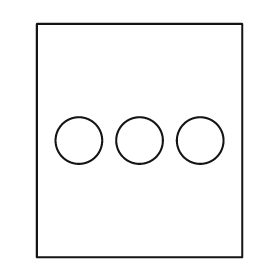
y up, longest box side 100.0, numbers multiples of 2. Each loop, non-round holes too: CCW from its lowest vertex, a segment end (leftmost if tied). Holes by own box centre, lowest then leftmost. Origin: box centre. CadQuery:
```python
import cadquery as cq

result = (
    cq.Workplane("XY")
    .moveTo(-44.0, -50.0)
    .lineTo(44.0, -50.0)
    .lineTo(44.0, 50.0)
    .lineTo(-44.0, 50.0)
    .close()
    .moveTo(-26.0, 0.0)
    .circle(10.0)
    .moveTo(0.0, 0.0)
    .circle(10.0)
    .moveTo(26.0, 0.0)
    .circle(10.0)
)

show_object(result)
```